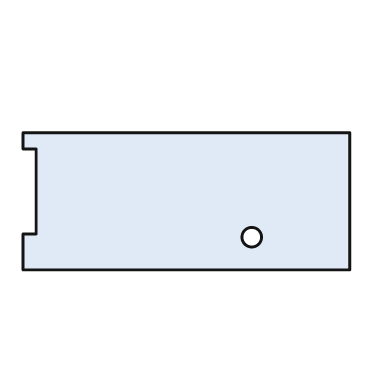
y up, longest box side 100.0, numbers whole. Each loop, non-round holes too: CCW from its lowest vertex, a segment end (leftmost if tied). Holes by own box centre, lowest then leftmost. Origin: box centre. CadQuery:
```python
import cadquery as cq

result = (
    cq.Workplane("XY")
    .moveTo(-50.0, -21.0)
    .lineTo(50.0, -21.0)
    .lineTo(50.0, 21.0)
    .lineTo(-50.0, 21.0)
    .lineTo(-50.0, 16.0)
    .lineTo(-46.0, 16.0)
    .lineTo(-46.0, -10.0)
    .lineTo(-50.0, -10.0)
    .close()
    .moveTo(20.0, -11.0)
    .circle(3.0)
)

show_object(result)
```